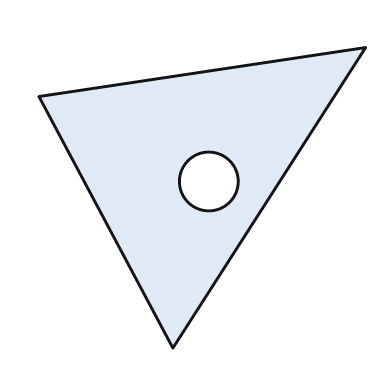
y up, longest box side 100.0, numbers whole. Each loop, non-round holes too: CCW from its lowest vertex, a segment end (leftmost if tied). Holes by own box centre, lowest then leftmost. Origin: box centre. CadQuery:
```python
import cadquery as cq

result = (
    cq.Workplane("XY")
    .moveTo(-9.0, -46.0)
    .lineTo(50.0, 46.0)
    .lineTo(-50.0, 31.0)
    .close()
    .moveTo(2.0, 5.0)
    .circle(9.0)
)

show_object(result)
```